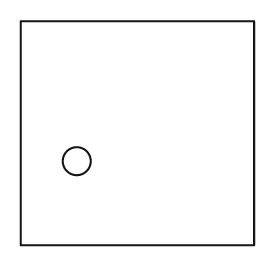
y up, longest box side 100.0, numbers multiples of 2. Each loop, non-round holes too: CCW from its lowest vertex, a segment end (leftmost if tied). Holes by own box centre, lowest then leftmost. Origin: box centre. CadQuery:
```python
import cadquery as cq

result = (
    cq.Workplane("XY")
    .moveTo(-50.0, -48.0)
    .lineTo(50.0, -48.0)
    .lineTo(50.0, 48.0)
    .lineTo(-50.0, 48.0)
    .close()
    .moveTo(-26.0, -12.0)
    .circle(6.0)
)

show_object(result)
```